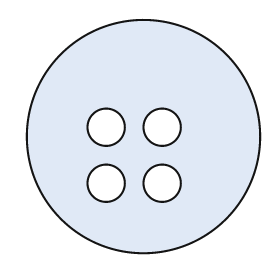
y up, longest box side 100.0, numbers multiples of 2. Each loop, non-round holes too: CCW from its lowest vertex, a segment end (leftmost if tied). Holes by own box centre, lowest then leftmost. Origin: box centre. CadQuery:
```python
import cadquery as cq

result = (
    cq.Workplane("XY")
    .moveTo(0.0, 0.0)
    .circle(50.0)
    .moveTo(-16.0, -20.0)
    .circle(8.0)
    .moveTo(8.0, -20.0)
    .circle(8.0)
    .moveTo(-16.0, 4.0)
    .circle(8.0)
    .moveTo(8.0, 4.0)
    .circle(8.0)
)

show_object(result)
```